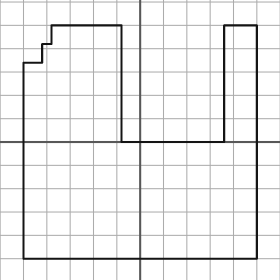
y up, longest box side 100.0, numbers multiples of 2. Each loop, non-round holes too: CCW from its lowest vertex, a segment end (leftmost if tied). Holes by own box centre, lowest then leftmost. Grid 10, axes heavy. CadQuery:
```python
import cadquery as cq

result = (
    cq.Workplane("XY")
    .moveTo(-50.0, -50.0)
    .lineTo(50.0, -50.0)
    .lineTo(50.0, 50.0)
    .lineTo(36.0, 50.0)
    .lineTo(36.0, 0.0)
    .lineTo(-8.0, 0.0)
    .lineTo(-8.0, 50.0)
    .lineTo(-38.0, 50.0)
    .lineTo(-38.0, 42.0)
    .lineTo(-42.0, 42.0)
    .lineTo(-42.0, 34.0)
    .lineTo(-50.0, 34.0)
    .close()
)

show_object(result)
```